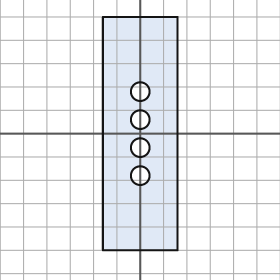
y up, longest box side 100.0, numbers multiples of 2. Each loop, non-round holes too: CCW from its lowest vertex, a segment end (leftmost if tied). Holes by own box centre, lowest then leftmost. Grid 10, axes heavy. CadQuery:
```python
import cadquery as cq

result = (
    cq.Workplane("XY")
    .moveTo(-16.0, -50.0)
    .lineTo(16.0, -50.0)
    .lineTo(16.0, 50.0)
    .lineTo(-16.0, 50.0)
    .close()
    .moveTo(0.0, -18.0)
    .circle(4.0)
    .moveTo(0.0, -6.0)
    .circle(4.0)
    .moveTo(0.0, 6.0)
    .circle(4.0)
    .moveTo(0.0, 18.0)
    .circle(4.0)
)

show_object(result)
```